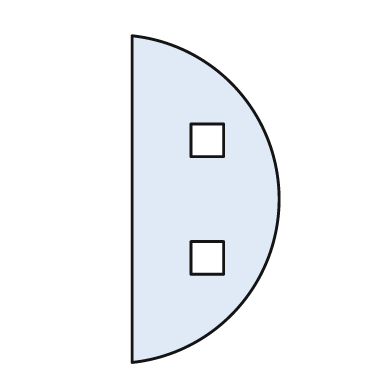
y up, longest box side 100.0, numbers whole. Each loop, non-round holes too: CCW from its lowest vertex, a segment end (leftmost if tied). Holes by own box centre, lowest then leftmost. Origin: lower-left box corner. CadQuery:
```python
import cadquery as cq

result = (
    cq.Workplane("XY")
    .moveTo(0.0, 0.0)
    .threePointArc((45.0, 50.0), (0.0, 100.0))
    .close()
    .moveTo(18.0, 27.0)
    .lineTo(28.0, 27.0)
    .lineTo(28.0, 37.0)
    .lineTo(18.0, 37.0)
    .close()
    .moveTo(18.0, 63.0)
    .lineTo(28.0, 63.0)
    .lineTo(28.0, 73.0)
    .lineTo(18.0, 73.0)
    .close()
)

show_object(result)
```